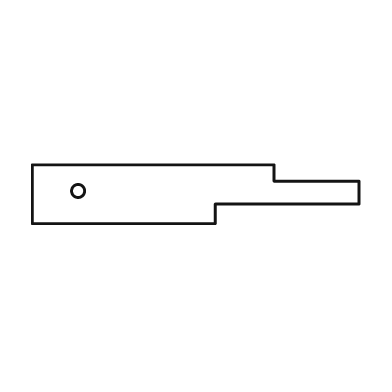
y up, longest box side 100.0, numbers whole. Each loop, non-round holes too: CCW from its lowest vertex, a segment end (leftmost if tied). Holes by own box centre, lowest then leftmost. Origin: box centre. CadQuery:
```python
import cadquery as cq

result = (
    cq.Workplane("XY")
    .moveTo(-50.0, -9.0)
    .lineTo(6.0, -9.0)
    .lineTo(6.0, -3.0)
    .lineTo(50.0, -3.0)
    .lineTo(50.0, 4.0)
    .lineTo(24.0, 4.0)
    .lineTo(24.0, 9.0)
    .lineTo(-50.0, 9.0)
    .close()
    .moveTo(-36.0, 1.0)
    .circle(2.0)
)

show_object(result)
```